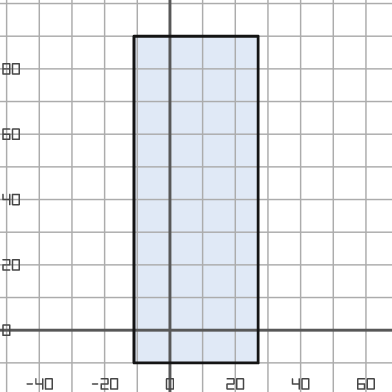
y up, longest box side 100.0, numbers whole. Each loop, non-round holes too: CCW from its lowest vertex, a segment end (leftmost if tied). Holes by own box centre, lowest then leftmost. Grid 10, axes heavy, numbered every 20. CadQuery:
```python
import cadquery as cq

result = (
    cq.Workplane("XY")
    .moveTo(-11.0, -10.0)
    .lineTo(27.0, -10.0)
    .lineTo(27.0, 90.0)
    .lineTo(-11.0, 90.0)
    .close()
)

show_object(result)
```